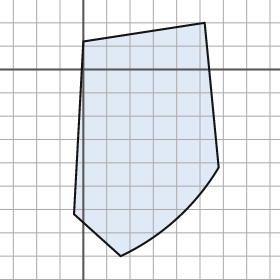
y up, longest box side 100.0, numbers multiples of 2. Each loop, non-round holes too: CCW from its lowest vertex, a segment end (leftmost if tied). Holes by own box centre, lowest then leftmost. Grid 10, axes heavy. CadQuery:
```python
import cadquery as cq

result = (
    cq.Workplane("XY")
    .moveTo(16.0, -80.0)
    .threePointArc((40.0, -64.0), (58.0, -42.0))
    .lineTo(52.0, 20.0)
    .lineTo(0.0, 12.0)
    .lineTo(-4.0, -62.0)
    .close()
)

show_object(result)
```